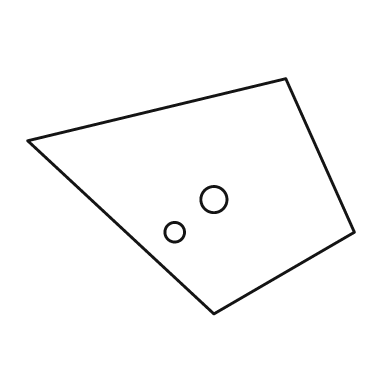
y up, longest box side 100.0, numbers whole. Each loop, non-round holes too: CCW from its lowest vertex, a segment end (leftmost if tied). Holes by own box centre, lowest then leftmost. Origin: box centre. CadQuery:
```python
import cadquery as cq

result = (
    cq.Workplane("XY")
    .moveTo(7.0, -36.0)
    .lineTo(50.0, -11.0)
    .lineTo(29.0, 36.0)
    .lineTo(-50.0, 17.0)
    .close()
    .moveTo(-5.0, -11.0)
    .circle(3.0)
    .moveTo(7.0, -1.0)
    .circle(4.0)
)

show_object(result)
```